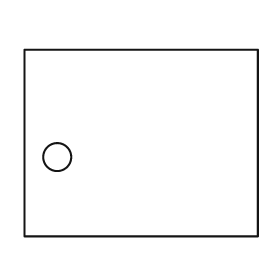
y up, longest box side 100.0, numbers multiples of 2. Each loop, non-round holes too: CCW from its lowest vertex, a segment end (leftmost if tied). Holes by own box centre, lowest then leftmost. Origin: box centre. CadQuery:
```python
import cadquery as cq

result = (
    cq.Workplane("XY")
    .moveTo(-50.0, -40.0)
    .lineTo(50.0, -40.0)
    .lineTo(50.0, 40.0)
    .lineTo(-50.0, 40.0)
    .close()
    .moveTo(-36.0, -6.0)
    .circle(6.0)
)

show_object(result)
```